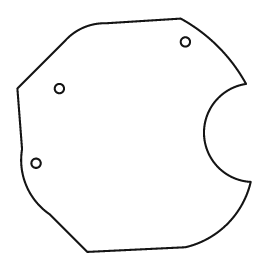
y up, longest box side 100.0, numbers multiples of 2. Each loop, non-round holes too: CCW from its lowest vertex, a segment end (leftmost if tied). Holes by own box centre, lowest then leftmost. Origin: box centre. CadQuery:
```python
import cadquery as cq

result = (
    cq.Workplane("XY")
    .moveTo(-20.0, -50.0)
    .lineTo(22.0, -48.0)
    .threePointArc((40.0, -38.0), (50.0, -20.0))
    .threePointArc((30.0, 0.0), (48.0, 22.0))
    .threePointArc((36.0, 38.0), (20.0, 50.0))
    .lineTo(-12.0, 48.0)
    .threePointArc((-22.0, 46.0), (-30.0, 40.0))
    .lineTo(-50.0, 20.0)
    .lineTo(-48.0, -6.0)
    .threePointArc((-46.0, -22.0), (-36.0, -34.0))
    .close()
    .moveTo(-42.0, -12.0)
    .circle(2.0)
    .moveTo(-32.0, 20.0)
    .circle(2.0)
    .moveTo(22.0, 40.0)
    .circle(2.0)
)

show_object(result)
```